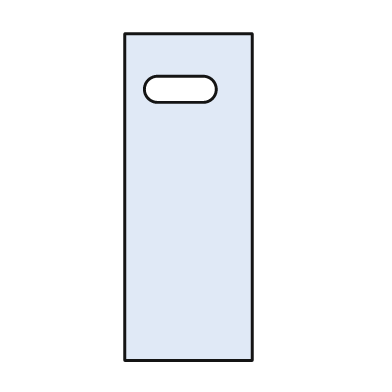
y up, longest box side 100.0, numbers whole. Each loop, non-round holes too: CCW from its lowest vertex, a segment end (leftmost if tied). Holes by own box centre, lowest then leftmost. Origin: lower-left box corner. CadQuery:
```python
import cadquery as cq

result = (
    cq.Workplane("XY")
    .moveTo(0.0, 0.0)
    .lineTo(39.0, 0.0)
    .lineTo(39.0, 100.0)
    .lineTo(0.0, 100.0)
    .close()
    .moveTo(10.0, 79.0)
    .lineTo(24.0, 79.0)
    .threePointArc((28.0, 83.0), (24.0, 87.0))
    .lineTo(10.0, 87.0)
    .threePointArc((6.0, 83.0), (10.0, 79.0))
    .close()
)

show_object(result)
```